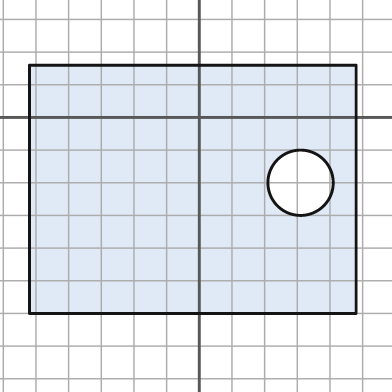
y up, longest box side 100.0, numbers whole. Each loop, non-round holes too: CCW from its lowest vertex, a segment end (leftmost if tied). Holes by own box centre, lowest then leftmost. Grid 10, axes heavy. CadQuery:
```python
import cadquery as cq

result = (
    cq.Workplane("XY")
    .moveTo(-52.0, -60.0)
    .lineTo(48.0, -60.0)
    .lineTo(48.0, 16.0)
    .lineTo(-52.0, 16.0)
    .close()
    .moveTo(31.0, -20.0)
    .circle(10.0)
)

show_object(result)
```